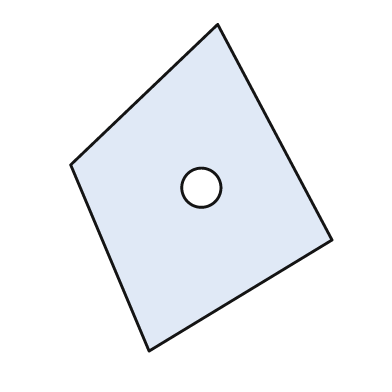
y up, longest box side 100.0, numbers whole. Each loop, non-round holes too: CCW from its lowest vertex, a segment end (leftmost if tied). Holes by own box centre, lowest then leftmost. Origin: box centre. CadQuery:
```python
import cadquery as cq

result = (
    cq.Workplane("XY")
    .moveTo(-16.0, -50.0)
    .lineTo(40.0, -16.0)
    .lineTo(5.0, 50.0)
    .lineTo(-40.0, 7.0)
    .close()
    .moveTo(0.0, 0.0)
    .circle(6.0)
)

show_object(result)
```